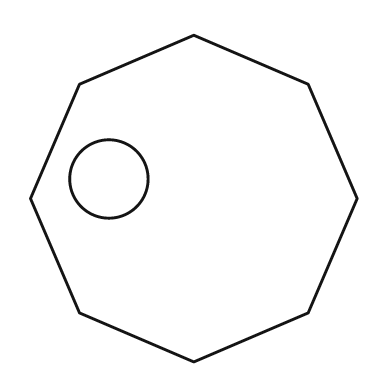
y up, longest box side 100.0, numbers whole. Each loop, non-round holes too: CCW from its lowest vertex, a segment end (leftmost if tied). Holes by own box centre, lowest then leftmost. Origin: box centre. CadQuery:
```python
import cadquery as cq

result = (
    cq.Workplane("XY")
    .moveTo(0.0, -50.0)
    .lineTo(35.0, -35.0)
    .lineTo(50.0, 0.0)
    .lineTo(35.0, 35.0)
    .lineTo(0.0, 50.0)
    .lineTo(-35.0, 35.0)
    .lineTo(-50.0, 0.0)
    .lineTo(-35.0, -35.0)
    .close()
    .moveTo(-26.0, 6.0)
    .circle(12.0)
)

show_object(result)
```